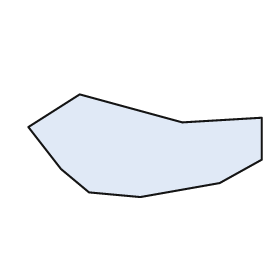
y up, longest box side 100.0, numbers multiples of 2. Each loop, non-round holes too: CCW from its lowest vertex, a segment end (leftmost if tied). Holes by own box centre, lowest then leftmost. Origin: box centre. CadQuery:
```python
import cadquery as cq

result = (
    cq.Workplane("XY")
    .moveTo(-2.0, -22.0)
    .lineTo(32.0, -16.0)
    .lineTo(50.0, -6.0)
    .lineTo(50.0, 12.0)
    .lineTo(16.0, 10.0)
    .lineTo(-28.0, 22.0)
    .lineTo(-50.0, 8.0)
    .lineTo(-36.0, -10.0)
    .lineTo(-24.0, -20.0)
    .close()
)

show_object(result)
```